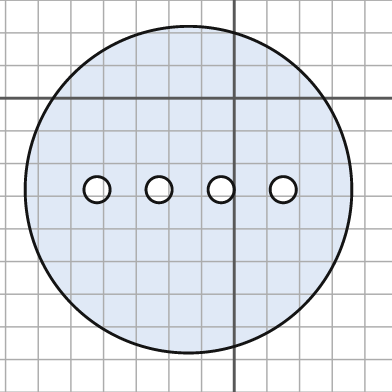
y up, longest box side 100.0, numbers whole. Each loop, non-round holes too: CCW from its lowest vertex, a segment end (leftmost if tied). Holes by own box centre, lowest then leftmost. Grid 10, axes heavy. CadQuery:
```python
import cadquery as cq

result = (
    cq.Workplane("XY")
    .moveTo(-14.0, -28.0)
    .circle(50.0)
    .moveTo(-42.0, -28.0)
    .circle(4.0)
    .moveTo(-23.0, -28.0)
    .circle(4.0)
    .moveTo(-4.0, -28.0)
    .circle(4.0)
    .moveTo(15.0, -28.0)
    .circle(4.0)
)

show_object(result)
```